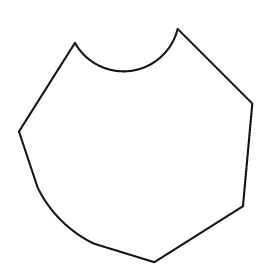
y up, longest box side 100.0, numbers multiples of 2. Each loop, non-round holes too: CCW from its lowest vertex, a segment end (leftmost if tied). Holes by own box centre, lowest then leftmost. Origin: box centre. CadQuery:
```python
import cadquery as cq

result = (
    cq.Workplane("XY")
    .moveTo(8.0, -50.0)
    .lineTo(46.0, -26.0)
    .lineTo(50.0, 18.0)
    .lineTo(18.0, 50.0)
    .threePointArc((-2.0, 32.0), (-26.0, 44.0))
    .lineTo(-50.0, 6.0)
    .lineTo(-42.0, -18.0)
    .threePointArc((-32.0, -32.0), (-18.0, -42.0))
    .close()
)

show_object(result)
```